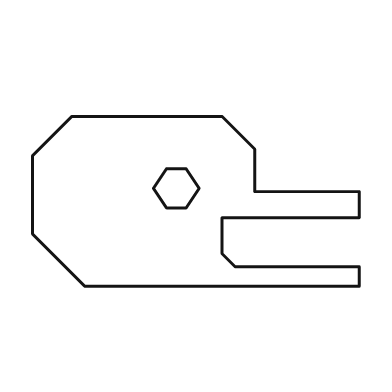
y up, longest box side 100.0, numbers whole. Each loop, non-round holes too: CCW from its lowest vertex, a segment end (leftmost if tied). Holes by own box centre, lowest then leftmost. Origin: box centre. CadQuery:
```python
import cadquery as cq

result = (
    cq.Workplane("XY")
    .moveTo(-34.0, -26.0)
    .lineTo(50.0, -26.0)
    .lineTo(50.0, -20.0)
    .lineTo(12.0, -20.0)
    .lineTo(8.0, -16.0)
    .lineTo(8.0, -5.0)
    .lineTo(50.0, -5.0)
    .lineTo(50.0, 3.0)
    .lineTo(18.0, 3.0)
    .lineTo(18.0, 16.0)
    .lineTo(8.0, 26.0)
    .lineTo(-38.0, 26.0)
    .lineTo(-50.0, 14.0)
    .lineTo(-50.0, -10.0)
    .close()
    .moveTo(-9.0, -2.0)
    .lineTo(-3.0, -2.0)
    .lineTo(1.0, 4.0)
    .lineTo(-3.0, 10.0)
    .lineTo(-9.0, 10.0)
    .lineTo(-13.0, 4.0)
    .close()
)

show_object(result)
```